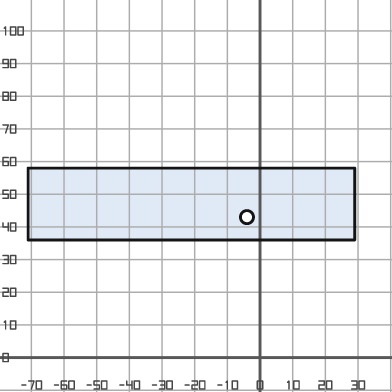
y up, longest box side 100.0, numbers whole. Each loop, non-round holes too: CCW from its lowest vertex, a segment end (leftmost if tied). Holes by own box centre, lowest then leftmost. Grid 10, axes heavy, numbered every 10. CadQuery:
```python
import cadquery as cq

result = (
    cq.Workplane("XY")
    .moveTo(-71.0, 36.0)
    .lineTo(29.0, 36.0)
    .lineTo(29.0, 58.0)
    .lineTo(-71.0, 58.0)
    .close()
    .moveTo(-4.0, 43.0)
    .circle(2.0)
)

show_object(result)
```